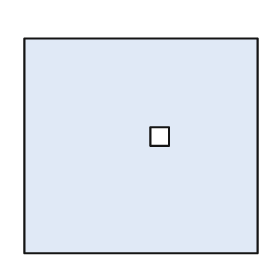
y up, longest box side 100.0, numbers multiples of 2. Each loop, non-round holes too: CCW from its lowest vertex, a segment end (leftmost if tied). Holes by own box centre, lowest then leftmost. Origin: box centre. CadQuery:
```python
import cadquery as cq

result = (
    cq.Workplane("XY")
    .moveTo(-50.0, -46.0)
    .lineTo(50.0, -46.0)
    .lineTo(50.0, 46.0)
    .lineTo(-50.0, 46.0)
    .close()
    .moveTo(4.0, 0.0)
    .lineTo(12.0, 0.0)
    .lineTo(12.0, 8.0)
    .lineTo(4.0, 8.0)
    .close()
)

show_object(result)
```